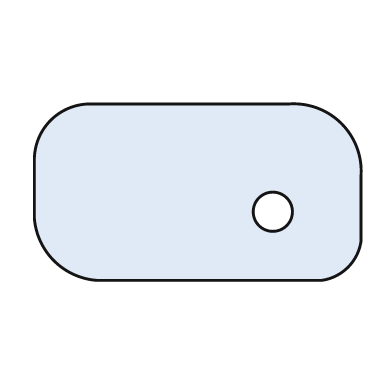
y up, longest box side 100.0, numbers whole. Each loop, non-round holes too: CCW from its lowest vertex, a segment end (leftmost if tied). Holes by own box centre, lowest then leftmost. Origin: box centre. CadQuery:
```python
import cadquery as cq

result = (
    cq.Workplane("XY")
    .moveTo(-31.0, -27.0)
    .lineTo(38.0, -27.0)
    .threePointArc((46.0, -23.0), (50.0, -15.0))
    .lineTo(50.0, 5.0)
    .threePointArc((44.0, 21.0), (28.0, 27.0))
    .lineTo(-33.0, 27.0)
    .threePointArc((-45.0, 22.0), (-50.0, 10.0))
    .lineTo(-50.0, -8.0)
    .threePointArc((-44.0, -21.0), (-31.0, -27.0))
    .close()
    .moveTo(23.0, -6.0)
    .circle(6.0)
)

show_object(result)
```